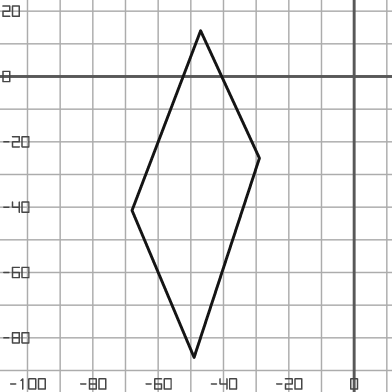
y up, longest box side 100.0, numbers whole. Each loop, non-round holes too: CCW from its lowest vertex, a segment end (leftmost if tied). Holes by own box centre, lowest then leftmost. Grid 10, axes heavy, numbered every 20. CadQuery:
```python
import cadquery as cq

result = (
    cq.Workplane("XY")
    .moveTo(-49.0, -86.0)
    .lineTo(-29.0, -25.0)
    .lineTo(-47.0, 14.0)
    .lineTo(-68.0, -41.0)
    .close()
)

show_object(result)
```